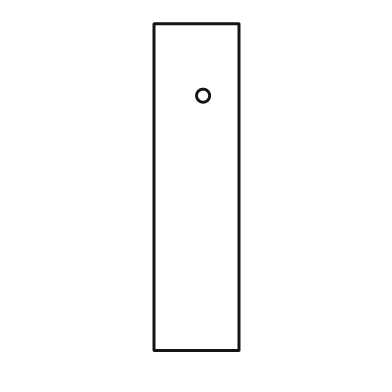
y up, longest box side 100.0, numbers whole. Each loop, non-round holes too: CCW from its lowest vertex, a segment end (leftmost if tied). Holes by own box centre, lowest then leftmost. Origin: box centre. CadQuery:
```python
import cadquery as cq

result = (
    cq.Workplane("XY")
    .moveTo(-13.0, -50.0)
    .lineTo(13.0, -50.0)
    .lineTo(13.0, 50.0)
    .lineTo(-13.0, 50.0)
    .close()
    .moveTo(2.0, 28.0)
    .circle(2.0)
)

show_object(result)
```